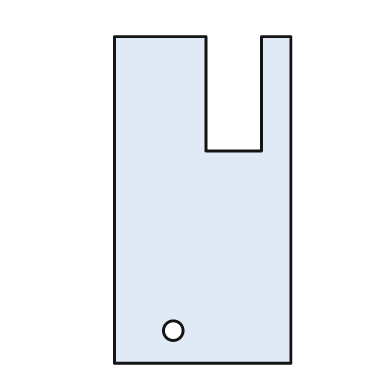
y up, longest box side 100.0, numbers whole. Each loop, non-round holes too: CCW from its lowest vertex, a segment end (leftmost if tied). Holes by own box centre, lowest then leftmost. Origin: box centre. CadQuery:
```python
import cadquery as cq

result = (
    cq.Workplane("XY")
    .moveTo(-27.0, -50.0)
    .lineTo(27.0, -50.0)
    .lineTo(27.0, 50.0)
    .lineTo(18.0, 50.0)
    .lineTo(18.0, 15.0)
    .lineTo(1.0, 15.0)
    .lineTo(1.0, 50.0)
    .lineTo(-27.0, 50.0)
    .close()
    .moveTo(-9.0, -40.0)
    .circle(3.0)
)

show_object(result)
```